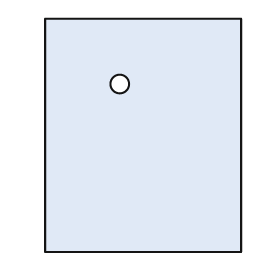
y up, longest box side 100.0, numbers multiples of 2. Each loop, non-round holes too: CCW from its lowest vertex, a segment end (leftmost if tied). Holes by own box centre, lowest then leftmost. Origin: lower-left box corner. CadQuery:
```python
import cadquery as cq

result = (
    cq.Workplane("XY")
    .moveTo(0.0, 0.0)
    .lineTo(84.0, 0.0)
    .lineTo(84.0, 100.0)
    .lineTo(0.0, 100.0)
    .close()
    .moveTo(32.0, 72.0)
    .circle(4.0)
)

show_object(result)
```